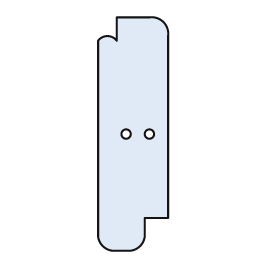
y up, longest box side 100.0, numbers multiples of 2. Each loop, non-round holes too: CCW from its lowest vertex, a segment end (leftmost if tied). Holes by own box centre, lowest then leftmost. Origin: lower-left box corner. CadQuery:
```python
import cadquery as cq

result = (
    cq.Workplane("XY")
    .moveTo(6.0, 0.0)
    .lineTo(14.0, 0.0)
    .threePointArc((18.0, 2.0), (20.0, 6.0))
    .lineTo(20.0, 14.0)
    .lineTo(30.0, 14.0)
    .lineTo(30.0, 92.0)
    .threePointArc((28.0, 98.0), (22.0, 100.0))
    .lineTo(8.0, 100.0)
    .lineTo(8.0, 90.0)
    .threePointArc((4.0, 92.0), (0.0, 90.0))
    .lineTo(0.0, 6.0)
    .threePointArc((2.0, 2.0), (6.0, 0.0))
    .close()
    .moveTo(12.0, 50.0)
    .circle(2.0)
    .moveTo(22.0, 50.0)
    .circle(2.0)
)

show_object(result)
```